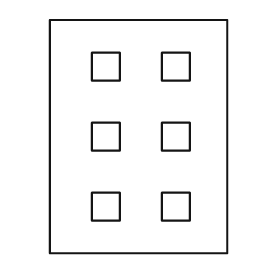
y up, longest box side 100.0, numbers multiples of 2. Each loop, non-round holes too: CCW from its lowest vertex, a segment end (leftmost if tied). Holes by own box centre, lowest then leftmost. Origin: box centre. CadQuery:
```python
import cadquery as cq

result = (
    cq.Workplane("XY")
    .moveTo(-38.0, -50.0)
    .lineTo(38.0, -50.0)
    .lineTo(38.0, 50.0)
    .lineTo(-38.0, 50.0)
    .close()
    .moveTo(-20.0, -36.0)
    .lineTo(-8.0, -36.0)
    .lineTo(-8.0, -24.0)
    .lineTo(-20.0, -24.0)
    .close()
    .moveTo(10.0, -36.0)
    .lineTo(22.0, -36.0)
    .lineTo(22.0, -24.0)
    .lineTo(10.0, -24.0)
    .close()
    .moveTo(-20.0, -6.0)
    .lineTo(-8.0, -6.0)
    .lineTo(-8.0, 6.0)
    .lineTo(-20.0, 6.0)
    .close()
    .moveTo(10.0, -6.0)
    .lineTo(22.0, -6.0)
    .lineTo(22.0, 6.0)
    .lineTo(10.0, 6.0)
    .close()
    .moveTo(-20.0, 24.0)
    .lineTo(-8.0, 24.0)
    .lineTo(-8.0, 36.0)
    .lineTo(-20.0, 36.0)
    .close()
    .moveTo(10.0, 24.0)
    .lineTo(22.0, 24.0)
    .lineTo(22.0, 36.0)
    .lineTo(10.0, 36.0)
    .close()
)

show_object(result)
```